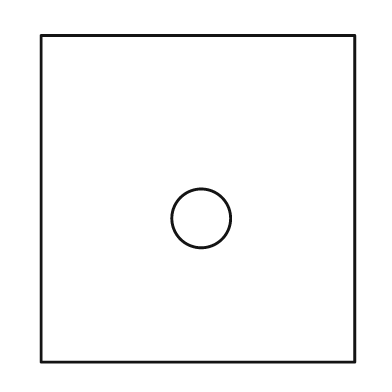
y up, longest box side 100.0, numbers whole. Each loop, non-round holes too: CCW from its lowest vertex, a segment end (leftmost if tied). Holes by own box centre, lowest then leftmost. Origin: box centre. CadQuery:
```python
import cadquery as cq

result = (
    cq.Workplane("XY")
    .moveTo(-48.0, -50.0)
    .lineTo(48.0, -50.0)
    .lineTo(48.0, 50.0)
    .lineTo(-48.0, 50.0)
    .close()
    .moveTo(1.0, -6.0)
    .circle(9.0)
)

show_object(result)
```